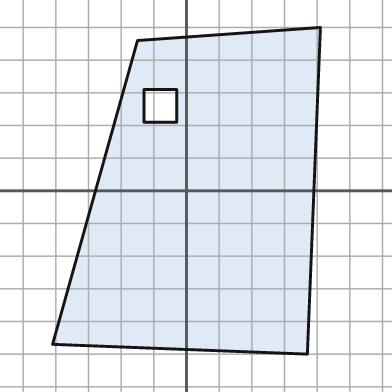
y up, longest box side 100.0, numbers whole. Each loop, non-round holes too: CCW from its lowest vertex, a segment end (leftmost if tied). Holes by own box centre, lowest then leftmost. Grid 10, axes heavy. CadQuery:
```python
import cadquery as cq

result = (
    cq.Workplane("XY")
    .moveTo(37.0, -50.0)
    .lineTo(41.0, 50.0)
    .lineTo(-15.0, 46.0)
    .lineTo(-41.0, -47.0)
    .close()
    .moveTo(-13.0, 21.0)
    .lineTo(-3.0, 21.0)
    .lineTo(-3.0, 31.0)
    .lineTo(-13.0, 31.0)
    .close()
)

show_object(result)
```